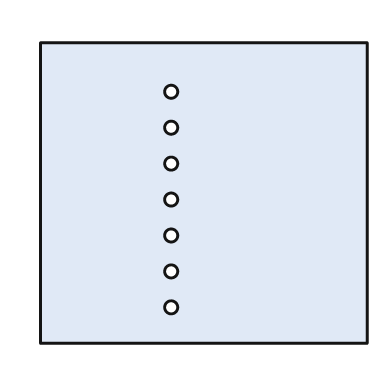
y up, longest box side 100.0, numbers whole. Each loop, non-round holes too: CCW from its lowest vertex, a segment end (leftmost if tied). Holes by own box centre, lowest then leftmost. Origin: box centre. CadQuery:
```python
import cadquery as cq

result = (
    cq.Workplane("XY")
    .moveTo(-50.0, -46.0)
    .lineTo(50.0, -46.0)
    .lineTo(50.0, 46.0)
    .lineTo(-50.0, 46.0)
    .close()
    .moveTo(-10.0, -35.0)
    .circle(2.0)
    .moveTo(-10.0, -24.0)
    .circle(2.0)
    .moveTo(-10.0, -13.0)
    .circle(2.0)
    .moveTo(-10.0, -2.0)
    .circle(2.0)
    .moveTo(-10.0, 9.0)
    .circle(2.0)
    .moveTo(-10.0, 20.0)
    .circle(2.0)
    .moveTo(-10.0, 31.0)
    .circle(2.0)
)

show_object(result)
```